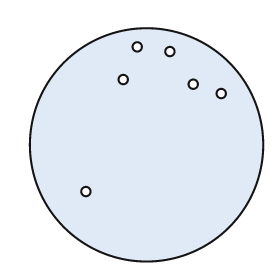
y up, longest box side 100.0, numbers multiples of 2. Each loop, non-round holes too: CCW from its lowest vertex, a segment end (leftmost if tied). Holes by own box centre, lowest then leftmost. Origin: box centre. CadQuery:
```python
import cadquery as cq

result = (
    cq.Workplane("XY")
    .moveTo(0.0, 0.0)
    .circle(50.0)
    .moveTo(-26.0, -20.0)
    .circle(2.0)
    .moveTo(32.0, 22.0)
    .circle(2.0)
    .moveTo(20.0, 26.0)
    .circle(2.0)
    .moveTo(-10.0, 28.0)
    .circle(2.0)
    .moveTo(10.0, 40.0)
    .circle(2.0)
    .moveTo(-4.0, 42.0)
    .circle(2.0)
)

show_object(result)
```